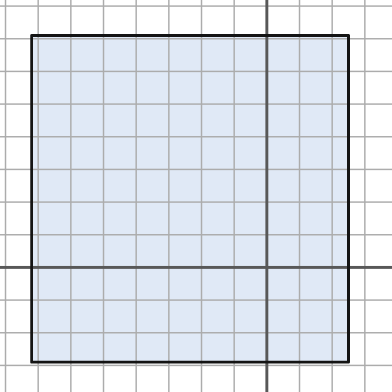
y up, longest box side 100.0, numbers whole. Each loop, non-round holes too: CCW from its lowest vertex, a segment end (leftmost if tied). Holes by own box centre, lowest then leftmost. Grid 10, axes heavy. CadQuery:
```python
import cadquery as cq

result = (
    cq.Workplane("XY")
    .moveTo(-72.0, -29.0)
    .lineTo(25.0, -29.0)
    .lineTo(25.0, 71.0)
    .lineTo(-72.0, 71.0)
    .close()
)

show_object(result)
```